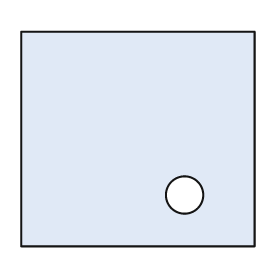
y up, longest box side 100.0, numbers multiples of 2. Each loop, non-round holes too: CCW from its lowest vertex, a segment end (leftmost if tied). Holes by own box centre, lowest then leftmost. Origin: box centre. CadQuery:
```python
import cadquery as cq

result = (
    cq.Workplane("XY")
    .moveTo(-50.0, -46.0)
    .lineTo(50.0, -46.0)
    .lineTo(50.0, 46.0)
    .lineTo(-50.0, 46.0)
    .close()
    .moveTo(20.0, -24.0)
    .circle(8.0)
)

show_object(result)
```